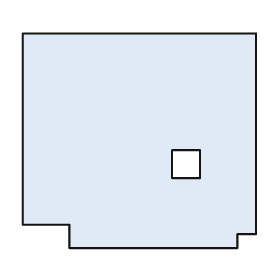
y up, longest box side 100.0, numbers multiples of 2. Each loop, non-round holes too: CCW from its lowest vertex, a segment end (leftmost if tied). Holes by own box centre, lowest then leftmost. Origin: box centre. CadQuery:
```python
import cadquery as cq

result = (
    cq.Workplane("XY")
    .moveTo(-30.0, -46.0)
    .lineTo(42.0, -46.0)
    .lineTo(42.0, -40.0)
    .lineTo(50.0, -40.0)
    .lineTo(50.0, 46.0)
    .lineTo(-50.0, 46.0)
    .lineTo(-50.0, -36.0)
    .lineTo(-30.0, -36.0)
    .close()
    .moveTo(14.0, -16.0)
    .lineTo(26.0, -16.0)
    .lineTo(26.0, -4.0)
    .lineTo(14.0, -4.0)
    .close()
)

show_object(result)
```